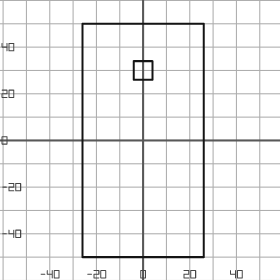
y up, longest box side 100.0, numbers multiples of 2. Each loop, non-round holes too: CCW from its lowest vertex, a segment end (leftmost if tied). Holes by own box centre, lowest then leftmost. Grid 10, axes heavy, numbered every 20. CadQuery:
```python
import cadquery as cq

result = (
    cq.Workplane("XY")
    .moveTo(-26.0, -50.0)
    .lineTo(26.0, -50.0)
    .lineTo(26.0, 50.0)
    .lineTo(-26.0, 50.0)
    .close()
    .moveTo(-4.0, 26.0)
    .lineTo(4.0, 26.0)
    .lineTo(4.0, 34.0)
    .lineTo(-4.0, 34.0)
    .close()
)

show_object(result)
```